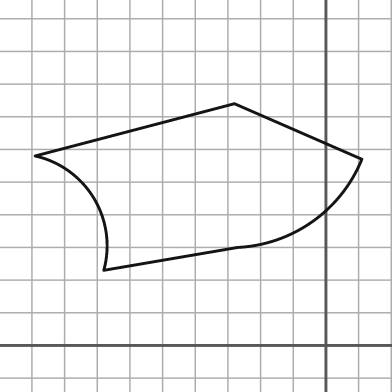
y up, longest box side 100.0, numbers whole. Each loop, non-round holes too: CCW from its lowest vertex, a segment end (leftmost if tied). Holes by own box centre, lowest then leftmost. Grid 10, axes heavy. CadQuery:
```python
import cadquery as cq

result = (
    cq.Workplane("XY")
    .moveTo(-68.0, 23.0)
    .lineTo(-27.0, 30.0)
    .threePointArc((-4.0, 38.0), (11.0, 57.0))
    .lineTo(-28.0, 74.0)
    .lineTo(-89.0, 58.0)
    .threePointArc((-71.0, 45.0), (-68.0, 23.0))
    .close()
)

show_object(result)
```